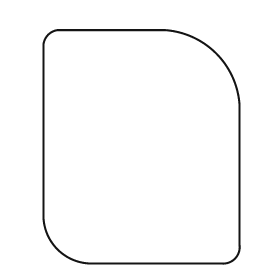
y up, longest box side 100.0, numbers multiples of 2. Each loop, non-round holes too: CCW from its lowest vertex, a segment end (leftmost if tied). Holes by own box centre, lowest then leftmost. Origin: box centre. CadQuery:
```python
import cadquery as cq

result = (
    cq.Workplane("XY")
    .moveTo(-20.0, -50.0)
    .lineTo(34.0, -50.0)
    .threePointArc((40.0, -48.0), (42.0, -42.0))
    .lineTo(42.0, 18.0)
    .threePointArc((32.0, 40.0), (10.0, 50.0))
    .lineTo(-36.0, 50.0)
    .threePointArc((-40.0, 48.0), (-42.0, 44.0))
    .lineTo(-42.0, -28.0)
    .threePointArc((-36.0, -44.0), (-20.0, -50.0))
    .close()
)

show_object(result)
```